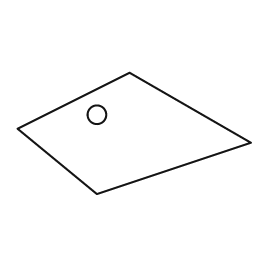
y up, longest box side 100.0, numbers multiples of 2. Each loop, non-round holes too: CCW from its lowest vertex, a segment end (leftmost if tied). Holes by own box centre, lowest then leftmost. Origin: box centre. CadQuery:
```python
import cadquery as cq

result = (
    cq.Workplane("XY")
    .moveTo(-16.0, -26.0)
    .lineTo(50.0, -4.0)
    .lineTo(-2.0, 26.0)
    .lineTo(-50.0, 2.0)
    .close()
    .moveTo(-16.0, 8.0)
    .circle(4.0)
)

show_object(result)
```